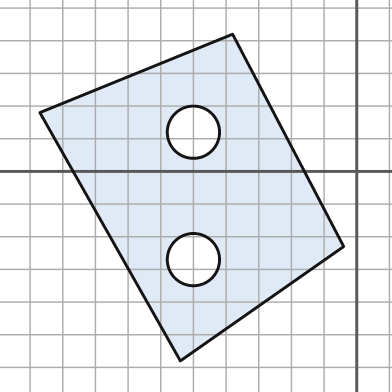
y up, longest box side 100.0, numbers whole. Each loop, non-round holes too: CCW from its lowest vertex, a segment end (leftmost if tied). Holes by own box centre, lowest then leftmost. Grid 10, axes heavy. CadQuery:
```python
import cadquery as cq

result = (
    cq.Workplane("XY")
    .moveTo(-54.0, -58.0)
    .lineTo(-4.0, -23.0)
    .lineTo(-38.0, 42.0)
    .lineTo(-97.0, 18.0)
    .close()
    .moveTo(-50.0, -27.0)
    .circle(8.0)
    .moveTo(-50.0, 12.0)
    .circle(8.0)
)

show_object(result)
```